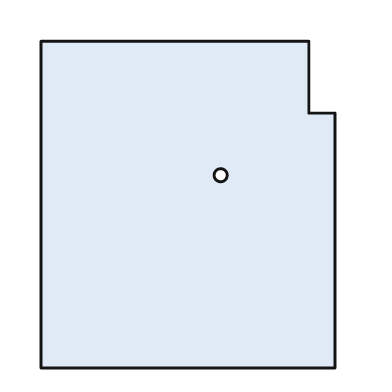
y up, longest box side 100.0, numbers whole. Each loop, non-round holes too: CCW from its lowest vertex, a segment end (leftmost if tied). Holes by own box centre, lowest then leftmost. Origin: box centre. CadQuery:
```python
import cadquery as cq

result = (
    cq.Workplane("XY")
    .moveTo(-45.0, -50.0)
    .lineTo(45.0, -50.0)
    .lineTo(45.0, 28.0)
    .lineTo(37.0, 28.0)
    .lineTo(37.0, 50.0)
    .lineTo(-45.0, 50.0)
    .close()
    .moveTo(10.0, 9.0)
    .circle(2.0)
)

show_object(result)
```